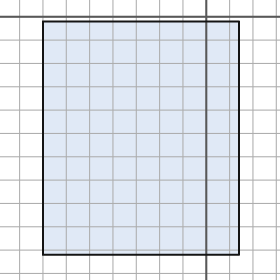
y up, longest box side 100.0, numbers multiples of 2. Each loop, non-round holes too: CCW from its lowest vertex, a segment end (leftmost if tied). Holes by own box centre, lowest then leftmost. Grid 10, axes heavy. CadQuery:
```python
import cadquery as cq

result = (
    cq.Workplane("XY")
    .moveTo(-70.0, -102.0)
    .lineTo(14.0, -102.0)
    .lineTo(14.0, -2.0)
    .lineTo(-70.0, -2.0)
    .close()
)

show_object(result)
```